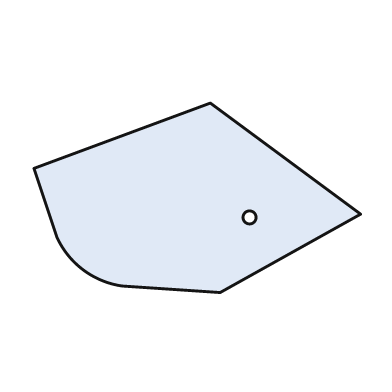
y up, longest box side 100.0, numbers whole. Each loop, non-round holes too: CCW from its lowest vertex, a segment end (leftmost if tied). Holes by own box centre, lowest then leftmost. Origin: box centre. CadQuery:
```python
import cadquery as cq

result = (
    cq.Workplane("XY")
    .moveTo(7.0, -29.0)
    .lineTo(50.0, -5.0)
    .lineTo(4.0, 29.0)
    .lineTo(-50.0, 9.0)
    .lineTo(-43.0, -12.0)
    .threePointArc((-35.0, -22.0), (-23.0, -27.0))
    .close()
    .moveTo(16.0, -6.0)
    .circle(2.0)
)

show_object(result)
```